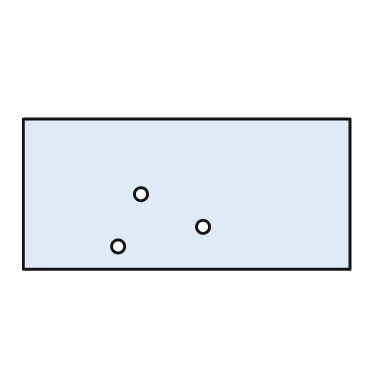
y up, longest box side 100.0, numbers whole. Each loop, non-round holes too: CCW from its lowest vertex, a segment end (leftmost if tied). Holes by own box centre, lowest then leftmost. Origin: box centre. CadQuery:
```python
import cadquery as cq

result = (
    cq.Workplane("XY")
    .moveTo(-50.0, -23.0)
    .lineTo(50.0, -23.0)
    .lineTo(50.0, 23.0)
    .lineTo(-50.0, 23.0)
    .close()
    .moveTo(-21.0, -16.0)
    .circle(2.0)
    .moveTo(5.0, -10.0)
    .circle(2.0)
    .moveTo(-14.0, 0.0)
    .circle(2.0)
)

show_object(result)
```